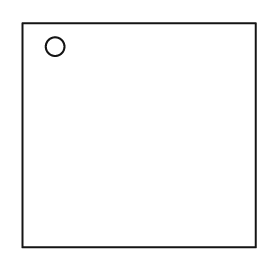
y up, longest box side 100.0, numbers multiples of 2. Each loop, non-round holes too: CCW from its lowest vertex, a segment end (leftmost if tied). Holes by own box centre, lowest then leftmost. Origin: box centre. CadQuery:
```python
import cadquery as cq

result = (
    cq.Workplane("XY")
    .moveTo(-50.0, -48.0)
    .lineTo(50.0, -48.0)
    .lineTo(50.0, 48.0)
    .lineTo(-50.0, 48.0)
    .close()
    .moveTo(-36.0, 38.0)
    .circle(4.0)
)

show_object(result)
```